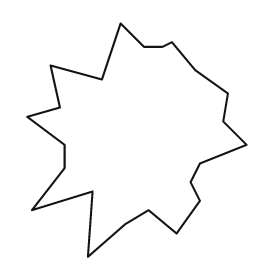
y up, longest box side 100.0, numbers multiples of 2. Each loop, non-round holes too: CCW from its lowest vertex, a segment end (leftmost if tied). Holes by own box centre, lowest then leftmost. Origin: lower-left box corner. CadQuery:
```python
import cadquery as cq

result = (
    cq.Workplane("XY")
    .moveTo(26.0, 0.0)
    .lineTo(42.0, 14.0)
    .lineTo(52.0, 20.0)
    .lineTo(64.0, 10.0)
    .lineTo(74.0, 24.0)
    .lineTo(70.0, 32.0)
    .lineTo(74.0, 40.0)
    .lineTo(94.0, 48.0)
    .lineTo(84.0, 58.0)
    .lineTo(86.0, 70.0)
    .lineTo(72.0, 80.0)
    .lineTo(62.0, 92.0)
    .lineTo(58.0, 90.0)
    .lineTo(50.0, 90.0)
    .lineTo(40.0, 100.0)
    .lineTo(32.0, 76.0)
    .lineTo(10.0, 82.0)
    .lineTo(14.0, 64.0)
    .lineTo(0.0, 60.0)
    .lineTo(16.0, 48.0)
    .lineTo(16.0, 38.0)
    .lineTo(2.0, 20.0)
    .lineTo(28.0, 28.0)
    .close()
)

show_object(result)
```